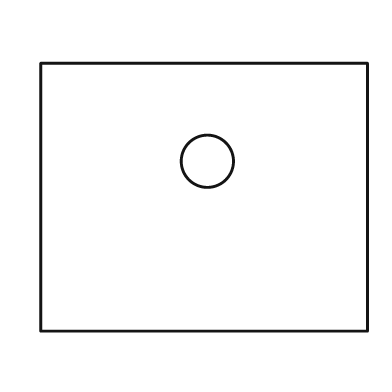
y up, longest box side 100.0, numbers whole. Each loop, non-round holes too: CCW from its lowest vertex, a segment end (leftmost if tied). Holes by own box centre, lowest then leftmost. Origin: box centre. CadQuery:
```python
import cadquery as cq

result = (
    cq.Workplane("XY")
    .moveTo(-50.0, -41.0)
    .lineTo(50.0, -41.0)
    .lineTo(50.0, 41.0)
    .lineTo(-50.0, 41.0)
    .close()
    .moveTo(1.0, 11.0)
    .circle(8.0)
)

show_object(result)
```